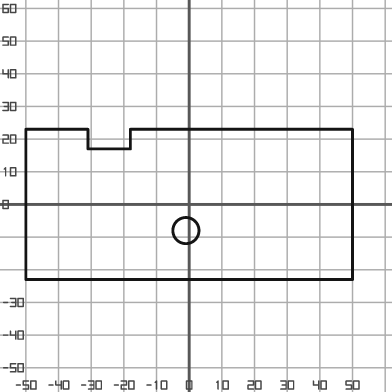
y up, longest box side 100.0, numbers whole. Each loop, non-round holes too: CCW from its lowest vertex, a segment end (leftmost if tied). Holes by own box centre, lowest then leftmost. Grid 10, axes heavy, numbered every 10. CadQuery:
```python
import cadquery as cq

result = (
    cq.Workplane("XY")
    .moveTo(-50.0, -23.0)
    .lineTo(50.0, -23.0)
    .lineTo(50.0, 23.0)
    .lineTo(-18.0, 23.0)
    .lineTo(-18.0, 17.0)
    .lineTo(-31.0, 17.0)
    .lineTo(-31.0, 23.0)
    .lineTo(-50.0, 23.0)
    .close()
    .moveTo(-1.0, -8.0)
    .circle(4.0)
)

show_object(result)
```